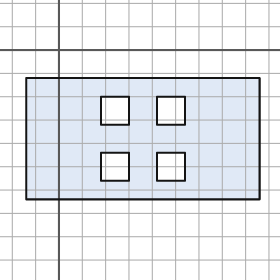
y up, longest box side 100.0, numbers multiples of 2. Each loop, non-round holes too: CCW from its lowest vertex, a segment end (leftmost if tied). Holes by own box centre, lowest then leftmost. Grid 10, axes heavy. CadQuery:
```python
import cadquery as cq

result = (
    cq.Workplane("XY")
    .moveTo(-14.0, -64.0)
    .lineTo(86.0, -64.0)
    .lineTo(86.0, -12.0)
    .lineTo(-14.0, -12.0)
    .close()
    .moveTo(18.0, -56.0)
    .lineTo(30.0, -56.0)
    .lineTo(30.0, -44.0)
    .lineTo(18.0, -44.0)
    .close()
    .moveTo(42.0, -56.0)
    .lineTo(54.0, -56.0)
    .lineTo(54.0, -44.0)
    .lineTo(42.0, -44.0)
    .close()
    .moveTo(18.0, -32.0)
    .lineTo(30.0, -32.0)
    .lineTo(30.0, -20.0)
    .lineTo(18.0, -20.0)
    .close()
    .moveTo(42.0, -32.0)
    .lineTo(54.0, -32.0)
    .lineTo(54.0, -20.0)
    .lineTo(42.0, -20.0)
    .close()
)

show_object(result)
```